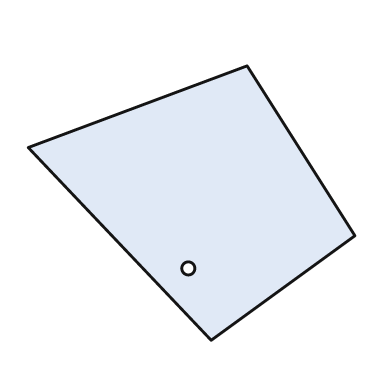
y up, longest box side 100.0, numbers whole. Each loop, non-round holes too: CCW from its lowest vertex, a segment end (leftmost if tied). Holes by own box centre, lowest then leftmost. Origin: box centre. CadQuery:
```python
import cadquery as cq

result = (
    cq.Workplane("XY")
    .moveTo(6.0, -42.0)
    .lineTo(50.0, -10.0)
    .lineTo(17.0, 42.0)
    .lineTo(-50.0, 17.0)
    .close()
    .moveTo(-1.0, -20.0)
    .circle(2.0)
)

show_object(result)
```